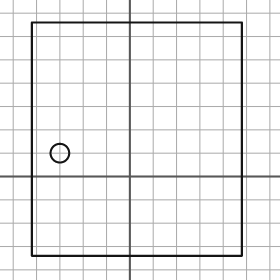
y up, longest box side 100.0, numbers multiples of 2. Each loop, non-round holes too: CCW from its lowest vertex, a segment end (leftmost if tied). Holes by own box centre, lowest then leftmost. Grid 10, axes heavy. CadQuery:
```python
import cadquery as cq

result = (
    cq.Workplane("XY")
    .moveTo(-42.0, -34.0)
    .lineTo(48.0, -34.0)
    .lineTo(48.0, 66.0)
    .lineTo(-42.0, 66.0)
    .close()
    .moveTo(-30.0, 10.0)
    .circle(4.0)
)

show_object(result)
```